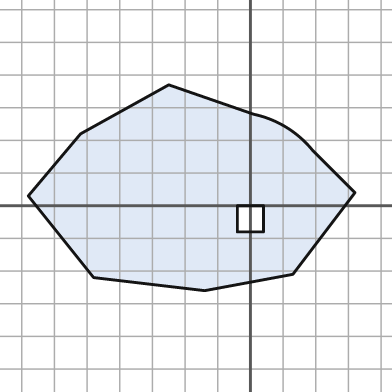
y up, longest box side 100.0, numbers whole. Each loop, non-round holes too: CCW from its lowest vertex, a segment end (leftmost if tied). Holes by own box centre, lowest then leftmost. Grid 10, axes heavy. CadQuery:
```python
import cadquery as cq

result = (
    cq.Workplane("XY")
    .moveTo(-14.0, -26.0)
    .lineTo(13.0, -21.0)
    .lineTo(32.0, 4.0)
    .lineTo(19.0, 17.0)
    .threePointArc((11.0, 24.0), (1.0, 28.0))
    .lineTo(-25.0, 37.0)
    .lineTo(-52.0, 22.0)
    .lineTo(-68.0, 3.0)
    .lineTo(-48.0, -22.0)
    .close()
    .moveTo(-4.0, -8.0)
    .lineTo(4.0, -8.0)
    .lineTo(4.0, 0.0)
    .lineTo(-4.0, 0.0)
    .close()
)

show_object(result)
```